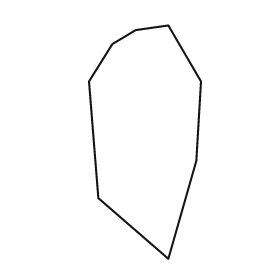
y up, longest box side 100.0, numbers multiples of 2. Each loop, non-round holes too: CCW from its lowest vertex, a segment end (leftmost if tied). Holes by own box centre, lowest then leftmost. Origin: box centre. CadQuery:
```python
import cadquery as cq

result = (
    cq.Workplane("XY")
    .moveTo(10.0, -50.0)
    .lineTo(22.0, -8.0)
    .lineTo(24.0, 26.0)
    .lineTo(10.0, 50.0)
    .lineTo(-4.0, 48.0)
    .lineTo(-14.0, 42.0)
    .lineTo(-24.0, 26.0)
    .lineTo(-20.0, -24.0)
    .close()
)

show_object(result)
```